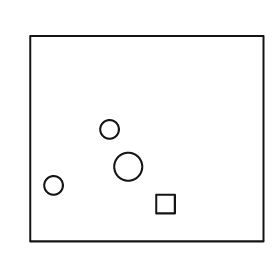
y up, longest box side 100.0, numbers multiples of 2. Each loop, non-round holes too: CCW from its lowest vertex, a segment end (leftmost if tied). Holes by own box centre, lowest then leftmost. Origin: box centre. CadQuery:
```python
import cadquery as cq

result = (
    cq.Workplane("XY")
    .moveTo(-50.0, -44.0)
    .lineTo(50.0, -44.0)
    .lineTo(50.0, 44.0)
    .lineTo(-50.0, 44.0)
    .close()
    .moveTo(4.0, -32.0)
    .lineTo(12.0, -32.0)
    .lineTo(12.0, -24.0)
    .lineTo(4.0, -24.0)
    .close()
    .moveTo(-40.0, -20.0)
    .circle(4.0)
    .moveTo(-8.0, -12.0)
    .circle(6.0)
    .moveTo(-16.0, 4.0)
    .circle(4.0)
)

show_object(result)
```